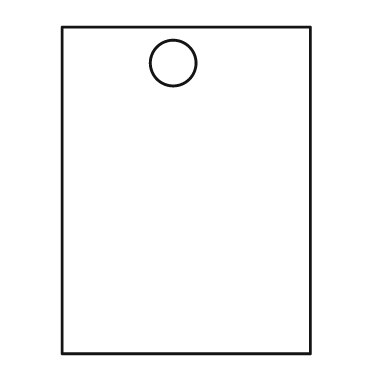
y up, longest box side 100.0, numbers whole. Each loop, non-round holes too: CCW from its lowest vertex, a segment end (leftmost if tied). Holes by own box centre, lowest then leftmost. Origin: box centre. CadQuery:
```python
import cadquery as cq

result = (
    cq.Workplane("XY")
    .moveTo(-38.0, -50.0)
    .lineTo(38.0, -50.0)
    .lineTo(38.0, 50.0)
    .lineTo(-38.0, 50.0)
    .close()
    .moveTo(-4.0, 39.0)
    .circle(7.0)
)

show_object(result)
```